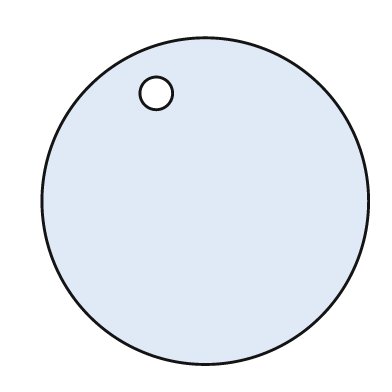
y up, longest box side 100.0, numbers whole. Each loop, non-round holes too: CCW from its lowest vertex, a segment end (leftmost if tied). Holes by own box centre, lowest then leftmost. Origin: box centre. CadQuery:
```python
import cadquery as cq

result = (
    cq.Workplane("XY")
    .moveTo(0.0, 0.0)
    .circle(50.0)
    .moveTo(-15.0, 33.0)
    .circle(5.0)
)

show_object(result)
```